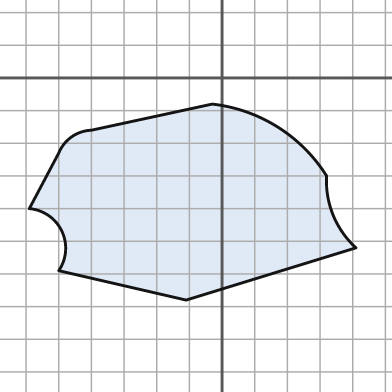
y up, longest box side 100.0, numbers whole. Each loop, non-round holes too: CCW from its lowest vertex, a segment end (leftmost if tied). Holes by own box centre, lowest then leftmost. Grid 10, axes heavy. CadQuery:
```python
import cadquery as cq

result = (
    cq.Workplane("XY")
    .moveTo(-11.0, -68.0)
    .lineTo(41.0, -52.0)
    .threePointArc((34.0, -42.0), (32.0, -30.0))
    .threePointArc((17.0, -15.0), (-3.0, -8.0))
    .lineTo(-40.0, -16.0)
    .threePointArc((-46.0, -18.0), (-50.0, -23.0))
    .lineTo(-59.0, -40.0)
    .threePointArc((-49.0, -47.0), (-50.0, -59.0))
    .close()
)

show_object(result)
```